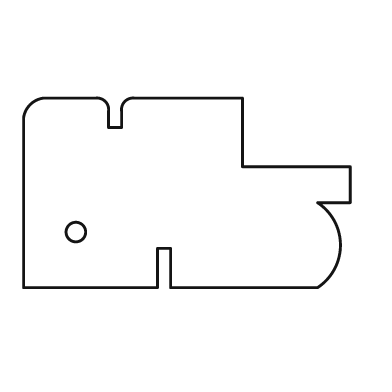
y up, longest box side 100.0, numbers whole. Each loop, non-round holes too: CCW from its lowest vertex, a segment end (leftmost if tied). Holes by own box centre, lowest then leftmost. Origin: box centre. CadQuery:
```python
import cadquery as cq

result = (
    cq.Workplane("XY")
    .moveTo(-50.0, -29.0)
    .lineTo(-9.0, -29.0)
    .lineTo(-9.0, -17.0)
    .lineTo(-5.0, -17.0)
    .lineTo(-5.0, -29.0)
    .lineTo(40.0, -29.0)
    .threePointArc((47.0, -16.0), (40.0, -3.0))
    .lineTo(50.0, -3.0)
    .lineTo(50.0, 8.0)
    .lineTo(17.0, 8.0)
    .lineTo(17.0, 29.0)
    .lineTo(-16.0, 29.0)
    .threePointArc((-19.0, 28.0), (-20.0, 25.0))
    .lineTo(-20.0, 20.0)
    .lineTo(-24.0, 20.0)
    .lineTo(-24.0, 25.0)
    .threePointArc((-25.0, 28.0), (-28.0, 29.0))
    .lineTo(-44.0, 29.0)
    .threePointArc((-48.0, 27.0), (-50.0, 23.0))
    .close()
    .moveTo(-34.0, -12.0)
    .circle(3.0)
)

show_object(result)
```